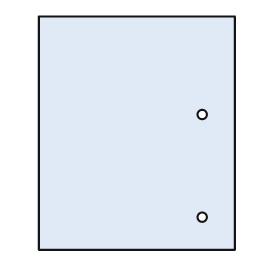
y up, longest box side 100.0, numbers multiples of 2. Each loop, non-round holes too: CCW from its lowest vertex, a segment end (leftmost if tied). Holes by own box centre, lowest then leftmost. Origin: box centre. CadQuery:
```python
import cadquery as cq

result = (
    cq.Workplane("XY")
    .moveTo(-42.0, -50.0)
    .lineTo(42.0, -50.0)
    .lineTo(42.0, 50.0)
    .lineTo(-42.0, 50.0)
    .close()
    .moveTo(28.0, -36.0)
    .circle(2.0)
    .moveTo(28.0, 8.0)
    .circle(2.0)
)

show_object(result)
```